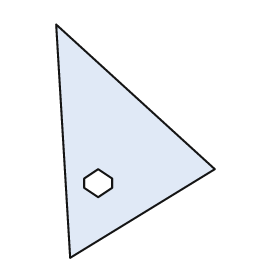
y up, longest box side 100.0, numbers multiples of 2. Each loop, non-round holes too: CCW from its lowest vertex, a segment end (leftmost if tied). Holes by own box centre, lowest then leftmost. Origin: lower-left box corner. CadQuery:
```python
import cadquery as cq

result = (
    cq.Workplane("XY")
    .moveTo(6.0, 0.0)
    .lineTo(68.0, 38.0)
    .lineTo(0.0, 100.0)
    .close()
    .moveTo(18.0, 26.0)
    .lineTo(24.0, 30.0)
    .lineTo(24.0, 34.0)
    .lineTo(18.0, 38.0)
    .lineTo(12.0, 34.0)
    .lineTo(12.0, 30.0)
    .close()
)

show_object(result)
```